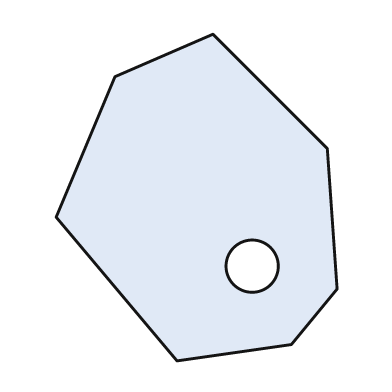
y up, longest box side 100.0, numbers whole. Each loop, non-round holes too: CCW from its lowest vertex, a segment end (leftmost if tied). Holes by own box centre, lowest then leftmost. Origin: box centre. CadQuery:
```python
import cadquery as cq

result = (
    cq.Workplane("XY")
    .moveTo(-6.0, -50.0)
    .lineTo(29.0, -45.0)
    .lineTo(43.0, -28.0)
    .lineTo(40.0, 15.0)
    .lineTo(5.0, 50.0)
    .lineTo(-25.0, 37.0)
    .lineTo(-43.0, -6.0)
    .close()
    .moveTo(17.0, -21.0)
    .circle(8.0)
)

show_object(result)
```